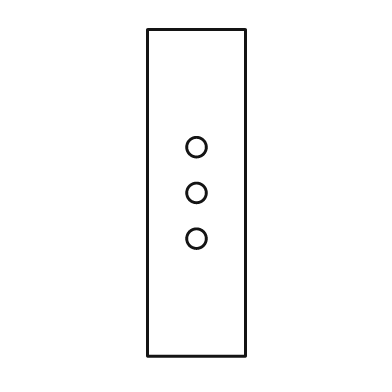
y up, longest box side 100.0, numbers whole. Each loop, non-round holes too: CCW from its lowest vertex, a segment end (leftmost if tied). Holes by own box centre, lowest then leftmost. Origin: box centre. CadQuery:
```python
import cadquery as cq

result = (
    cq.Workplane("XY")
    .moveTo(-15.0, -50.0)
    .lineTo(15.0, -50.0)
    .lineTo(15.0, 50.0)
    .lineTo(-15.0, 50.0)
    .close()
    .moveTo(0.0, -14.0)
    .circle(3.0)
    .moveTo(0.0, 0.0)
    .circle(3.0)
    .moveTo(0.0, 14.0)
    .circle(3.0)
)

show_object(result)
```